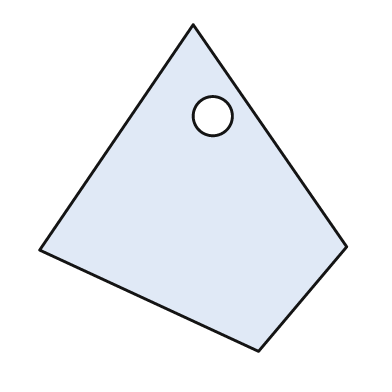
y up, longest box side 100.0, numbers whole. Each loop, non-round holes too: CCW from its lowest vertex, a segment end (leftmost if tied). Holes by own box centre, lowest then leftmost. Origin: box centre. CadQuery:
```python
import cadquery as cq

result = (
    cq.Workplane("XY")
    .moveTo(20.0, -50.0)
    .lineTo(47.0, -18.0)
    .lineTo(0.0, 50.0)
    .lineTo(-47.0, -19.0)
    .close()
    .moveTo(6.0, 22.0)
    .circle(6.0)
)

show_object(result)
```